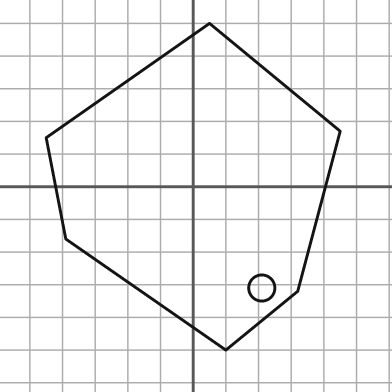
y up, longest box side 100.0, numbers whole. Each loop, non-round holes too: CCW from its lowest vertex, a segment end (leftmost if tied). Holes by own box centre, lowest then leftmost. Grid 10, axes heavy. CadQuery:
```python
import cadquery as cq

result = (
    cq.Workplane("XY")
    .moveTo(10.0, -50.0)
    .lineTo(32.0, -32.0)
    .lineTo(45.0, 17.0)
    .lineTo(5.0, 50.0)
    .lineTo(-45.0, 15.0)
    .lineTo(-39.0, -16.0)
    .close()
    .moveTo(21.0, -31.0)
    .circle(4.0)
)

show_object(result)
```